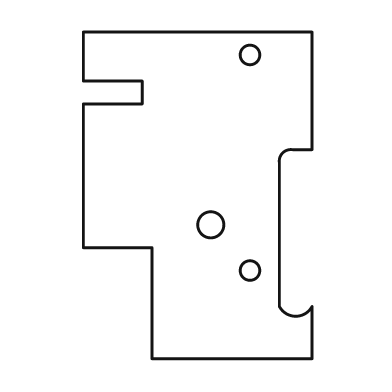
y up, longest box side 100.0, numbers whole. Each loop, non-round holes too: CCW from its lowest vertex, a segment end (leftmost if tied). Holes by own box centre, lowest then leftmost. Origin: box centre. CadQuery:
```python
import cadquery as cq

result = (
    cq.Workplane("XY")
    .moveTo(-14.0, -50.0)
    .lineTo(35.0, -50.0)
    .lineTo(35.0, -34.0)
    .threePointArc((30.0, -37.0), (25.0, -34.0))
    .lineTo(25.0, 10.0)
    .threePointArc((26.0, 13.0), (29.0, 14.0))
    .lineTo(35.0, 14.0)
    .lineTo(35.0, 50.0)
    .lineTo(-35.0, 50.0)
    .lineTo(-35.0, 35.0)
    .lineTo(-17.0, 35.0)
    .lineTo(-17.0, 28.0)
    .lineTo(-35.0, 28.0)
    .lineTo(-35.0, -16.0)
    .lineTo(-14.0, -16.0)
    .close()
    .moveTo(16.0, -23.0)
    .circle(3.0)
    .moveTo(4.0, -9.0)
    .circle(4.0)
    .moveTo(16.0, 43.0)
    .circle(3.0)
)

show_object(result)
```